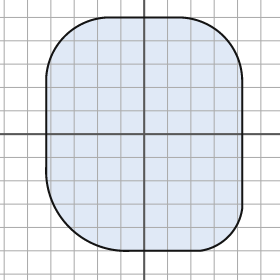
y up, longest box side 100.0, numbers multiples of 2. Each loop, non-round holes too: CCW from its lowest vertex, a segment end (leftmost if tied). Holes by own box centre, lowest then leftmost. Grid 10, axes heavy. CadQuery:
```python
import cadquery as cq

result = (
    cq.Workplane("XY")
    .moveTo(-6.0, -50.0)
    .lineTo(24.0, -50.0)
    .threePointArc((36.0, -44.0), (42.0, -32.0))
    .lineTo(42.0, 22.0)
    .threePointArc((34.0, 42.0), (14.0, 50.0))
    .lineTo(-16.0, 50.0)
    .threePointArc((-34.0, 42.0), (-42.0, 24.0))
    .lineTo(-42.0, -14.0)
    .threePointArc((-32.0, -40.0), (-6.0, -50.0))
    .close()
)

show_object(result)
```